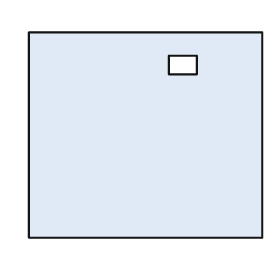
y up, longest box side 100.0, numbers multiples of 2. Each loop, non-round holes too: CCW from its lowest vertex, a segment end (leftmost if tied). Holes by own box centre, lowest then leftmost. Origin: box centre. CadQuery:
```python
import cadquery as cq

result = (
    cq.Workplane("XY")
    .moveTo(-50.0, -44.0)
    .lineTo(50.0, -44.0)
    .lineTo(50.0, 44.0)
    .lineTo(-50.0, 44.0)
    .close()
    .moveTo(10.0, 26.0)
    .lineTo(22.0, 26.0)
    .lineTo(22.0, 34.0)
    .lineTo(10.0, 34.0)
    .close()
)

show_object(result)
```